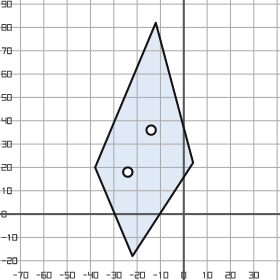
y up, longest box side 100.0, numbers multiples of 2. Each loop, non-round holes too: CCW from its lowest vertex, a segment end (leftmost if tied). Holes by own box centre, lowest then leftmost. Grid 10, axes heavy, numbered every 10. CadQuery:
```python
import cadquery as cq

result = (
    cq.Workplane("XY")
    .moveTo(-22.0, -18.0)
    .lineTo(4.0, 22.0)
    .lineTo(-12.0, 82.0)
    .lineTo(-38.0, 20.0)
    .close()
    .moveTo(-24.0, 18.0)
    .circle(2.0)
    .moveTo(-14.0, 36.0)
    .circle(2.0)
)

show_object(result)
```